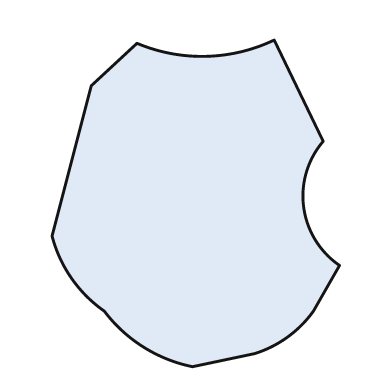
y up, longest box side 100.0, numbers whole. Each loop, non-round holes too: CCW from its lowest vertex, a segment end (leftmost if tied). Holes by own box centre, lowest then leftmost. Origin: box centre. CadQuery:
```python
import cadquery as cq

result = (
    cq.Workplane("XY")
    .moveTo(-1.0, -50.0)
    .lineTo(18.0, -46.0)
    .threePointArc((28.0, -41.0), (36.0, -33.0))
    .lineTo(44.0, -19.0)
    .threePointArc((33.0, -1.0), (39.0, 19.0))
    .lineTo(24.0, 50.0)
    .threePointArc((3.0, 45.0), (-18.0, 49.0))
    .lineTo(-32.0, 36.0)
    .lineTo(-44.0, -10.0)
    .threePointArc((-38.0, -23.0), (-28.0, -33.0))
    .threePointArc((-16.0, -44.0), (-1.0, -50.0))
    .close()
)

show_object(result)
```